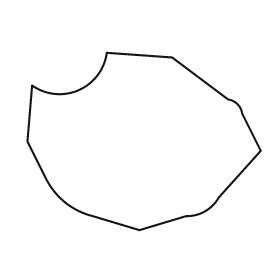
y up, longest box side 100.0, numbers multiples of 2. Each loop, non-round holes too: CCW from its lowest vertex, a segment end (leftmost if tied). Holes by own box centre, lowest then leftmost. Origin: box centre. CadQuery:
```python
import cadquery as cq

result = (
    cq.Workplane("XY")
    .moveTo(-2.0, -38.0)
    .lineTo(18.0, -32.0)
    .threePointArc((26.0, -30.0), (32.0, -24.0))
    .lineTo(50.0, -4.0)
    .lineTo(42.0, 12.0)
    .threePointArc((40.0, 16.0), (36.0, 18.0))
    .lineTo(12.0, 36.0)
    .lineTo(-16.0, 38.0)
    .threePointArc((-28.0, 22.0), (-48.0, 24.0))
    .lineTo(-50.0, 0.0)
    .lineTo(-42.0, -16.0)
    .threePointArc((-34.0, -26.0), (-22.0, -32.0))
    .close()
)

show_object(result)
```